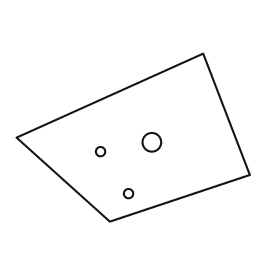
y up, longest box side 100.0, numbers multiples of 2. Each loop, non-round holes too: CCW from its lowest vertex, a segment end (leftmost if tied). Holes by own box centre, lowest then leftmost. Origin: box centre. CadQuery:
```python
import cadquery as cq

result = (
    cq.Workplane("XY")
    .moveTo(-10.0, -36.0)
    .lineTo(50.0, -16.0)
    .lineTo(30.0, 36.0)
    .lineTo(-50.0, 0.0)
    .close()
    .moveTo(-2.0, -24.0)
    .circle(2.0)
    .moveTo(-14.0, -6.0)
    .circle(2.0)
    .moveTo(8.0, -2.0)
    .circle(4.0)
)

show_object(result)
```